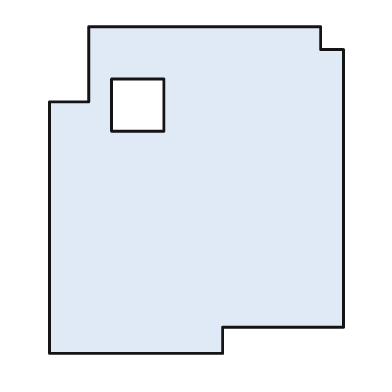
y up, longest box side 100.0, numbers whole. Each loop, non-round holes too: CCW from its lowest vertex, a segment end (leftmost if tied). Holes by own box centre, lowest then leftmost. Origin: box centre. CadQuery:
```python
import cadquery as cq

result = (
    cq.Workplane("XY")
    .moveTo(-45.0, -50.0)
    .lineTo(8.0, -50.0)
    .lineTo(8.0, -42.0)
    .lineTo(45.0, -42.0)
    .lineTo(45.0, 43.0)
    .lineTo(38.0, 43.0)
    .lineTo(38.0, 50.0)
    .lineTo(-33.0, 50.0)
    .lineTo(-33.0, 27.0)
    .lineTo(-45.0, 27.0)
    .close()
    .moveTo(-26.0, 18.0)
    .lineTo(-10.0, 18.0)
    .lineTo(-10.0, 34.0)
    .lineTo(-26.0, 34.0)
    .close()
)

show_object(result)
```